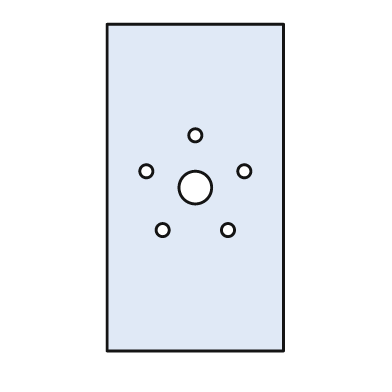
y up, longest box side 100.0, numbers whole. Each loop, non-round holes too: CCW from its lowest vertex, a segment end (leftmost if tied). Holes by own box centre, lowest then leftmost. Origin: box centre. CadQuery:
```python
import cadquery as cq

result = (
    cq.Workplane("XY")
    .moveTo(-27.0, -50.0)
    .lineTo(27.0, -50.0)
    .lineTo(27.0, 50.0)
    .lineTo(-27.0, 50.0)
    .close()
    .moveTo(-10.0, -13.0)
    .circle(2.0)
    .moveTo(10.0, -13.0)
    .circle(2.0)
    .moveTo(0.0, 0.0)
    .circle(5.0)
    .moveTo(-15.0, 5.0)
    .circle(2.0)
    .moveTo(15.0, 5.0)
    .circle(2.0)
    .moveTo(0.0, 16.0)
    .circle(2.0)
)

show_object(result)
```